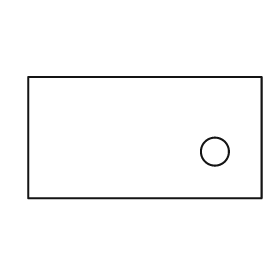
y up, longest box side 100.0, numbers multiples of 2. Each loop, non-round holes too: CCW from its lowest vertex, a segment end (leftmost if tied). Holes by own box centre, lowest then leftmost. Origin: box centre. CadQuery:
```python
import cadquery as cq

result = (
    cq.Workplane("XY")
    .moveTo(-50.0, -26.0)
    .lineTo(50.0, -26.0)
    .lineTo(50.0, 26.0)
    .lineTo(-50.0, 26.0)
    .close()
    .moveTo(30.0, -6.0)
    .circle(6.0)
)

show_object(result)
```